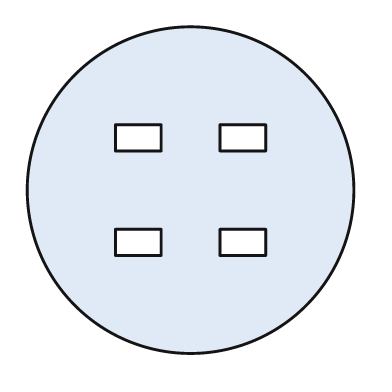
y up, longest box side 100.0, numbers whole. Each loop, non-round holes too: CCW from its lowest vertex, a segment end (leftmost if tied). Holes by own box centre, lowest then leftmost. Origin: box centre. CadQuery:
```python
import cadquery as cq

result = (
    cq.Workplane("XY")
    .moveTo(0.0, 0.0)
    .circle(50.0)
    .moveTo(-23.0, -20.0)
    .lineTo(-9.0, -20.0)
    .lineTo(-9.0, -12.0)
    .lineTo(-23.0, -12.0)
    .close()
    .moveTo(9.0, -20.0)
    .lineTo(23.0, -20.0)
    .lineTo(23.0, -12.0)
    .lineTo(9.0, -12.0)
    .close()
    .moveTo(-23.0, 12.0)
    .lineTo(-9.0, 12.0)
    .lineTo(-9.0, 20.0)
    .lineTo(-23.0, 20.0)
    .close()
    .moveTo(9.0, 12.0)
    .lineTo(23.0, 12.0)
    .lineTo(23.0, 20.0)
    .lineTo(9.0, 20.0)
    .close()
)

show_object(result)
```